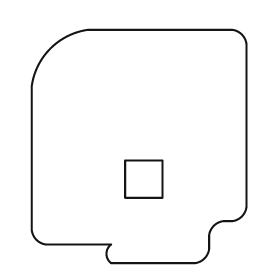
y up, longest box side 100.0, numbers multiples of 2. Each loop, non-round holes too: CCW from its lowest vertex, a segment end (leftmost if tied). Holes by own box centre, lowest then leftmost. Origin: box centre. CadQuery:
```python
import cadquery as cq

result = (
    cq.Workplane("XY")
    .moveTo(-12.0, -50.0)
    .lineTo(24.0, -50.0)
    .threePointArc((28.0, -48.0), (30.0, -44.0))
    .lineTo(30.0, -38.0)
    .threePointArc((32.0, -34.0), (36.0, -32.0))
    .lineTo(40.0, -32.0)
    .threePointArc((44.0, -30.0), (46.0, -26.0))
    .lineTo(46.0, 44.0)
    .threePointArc((44.0, 48.0), (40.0, 50.0))
    .lineTo(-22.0, 50.0)
    .threePointArc((-38.0, 42.0), (-46.0, 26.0))
    .lineTo(-46.0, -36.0)
    .threePointArc((-44.0, -40.0), (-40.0, -42.0))
    .lineTo(-12.0, -42.0)
    .threePointArc((-14.0, -46.0), (-12.0, -50.0))
    .close()
    .moveTo(-6.0, -22.0)
    .lineTo(10.0, -22.0)
    .lineTo(10.0, -6.0)
    .lineTo(-6.0, -6.0)
    .close()
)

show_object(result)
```